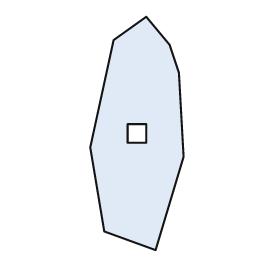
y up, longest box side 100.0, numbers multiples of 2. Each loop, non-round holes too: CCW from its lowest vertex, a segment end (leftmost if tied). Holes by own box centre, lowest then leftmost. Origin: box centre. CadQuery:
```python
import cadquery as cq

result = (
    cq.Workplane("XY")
    .moveTo(8.0, -50.0)
    .lineTo(20.0, -10.0)
    .lineTo(18.0, 26.0)
    .lineTo(14.0, 38.0)
    .lineTo(4.0, 50.0)
    .lineTo(-10.0, 40.0)
    .lineTo(-20.0, -6.0)
    .lineTo(-14.0, -42.0)
    .close()
    .moveTo(-4.0, -4.0)
    .lineTo(4.0, -4.0)
    .lineTo(4.0, 4.0)
    .lineTo(-4.0, 4.0)
    .close()
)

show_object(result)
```